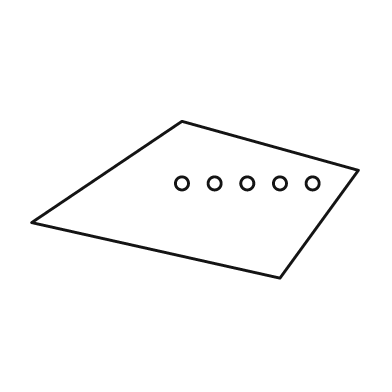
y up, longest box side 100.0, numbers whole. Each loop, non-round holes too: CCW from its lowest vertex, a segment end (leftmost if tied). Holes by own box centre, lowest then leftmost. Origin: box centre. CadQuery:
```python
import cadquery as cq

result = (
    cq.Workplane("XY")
    .moveTo(26.0, -24.0)
    .lineTo(50.0, 9.0)
    .lineTo(-4.0, 24.0)
    .lineTo(-50.0, -7.0)
    .close()
    .moveTo(-4.0, 5.0)
    .circle(2.0)
    .moveTo(6.0, 5.0)
    .circle(2.0)
    .moveTo(16.0, 5.0)
    .circle(2.0)
    .moveTo(26.0, 5.0)
    .circle(2.0)
    .moveTo(36.0, 5.0)
    .circle(2.0)
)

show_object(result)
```